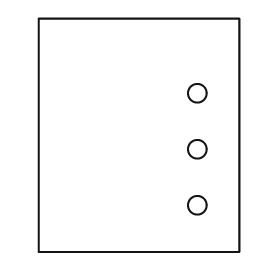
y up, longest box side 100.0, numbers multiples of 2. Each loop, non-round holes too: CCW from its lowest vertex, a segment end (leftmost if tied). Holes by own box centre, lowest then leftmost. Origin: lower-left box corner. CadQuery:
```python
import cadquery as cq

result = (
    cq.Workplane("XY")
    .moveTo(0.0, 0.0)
    .lineTo(86.0, 0.0)
    .lineTo(86.0, 100.0)
    .lineTo(0.0, 100.0)
    .close()
    .moveTo(68.0, 20.0)
    .circle(4.0)
    .moveTo(68.0, 44.0)
    .circle(4.0)
    .moveTo(68.0, 68.0)
    .circle(4.0)
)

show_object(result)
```